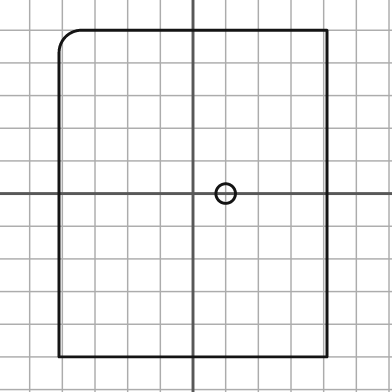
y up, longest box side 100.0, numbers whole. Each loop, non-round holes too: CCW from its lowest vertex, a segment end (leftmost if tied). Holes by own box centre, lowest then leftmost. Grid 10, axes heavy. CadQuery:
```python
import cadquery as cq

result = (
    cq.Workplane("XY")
    .moveTo(-41.0, -50.0)
    .lineTo(41.0, -50.0)
    .lineTo(41.0, 50.0)
    .lineTo(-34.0, 50.0)
    .threePointArc((-39.0, 48.0), (-41.0, 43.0))
    .close()
    .moveTo(10.0, 0.0)
    .circle(3.0)
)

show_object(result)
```